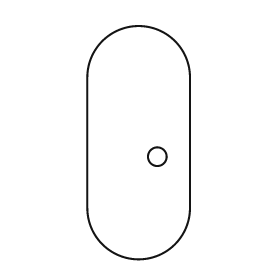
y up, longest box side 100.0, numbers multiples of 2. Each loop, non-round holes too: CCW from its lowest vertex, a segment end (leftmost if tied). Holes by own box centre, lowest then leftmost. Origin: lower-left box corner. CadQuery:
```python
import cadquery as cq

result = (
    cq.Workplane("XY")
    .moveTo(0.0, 22.0)
    .threePointArc((22.0, 0.0), (44.0, 22.0))
    .lineTo(44.0, 78.0)
    .threePointArc((22.0, 100.0), (0.0, 78.0))
    .close()
    .moveTo(30.0, 44.0)
    .circle(4.0)
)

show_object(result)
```